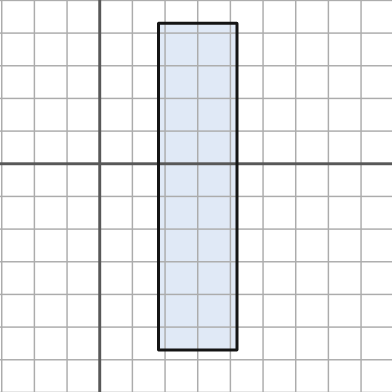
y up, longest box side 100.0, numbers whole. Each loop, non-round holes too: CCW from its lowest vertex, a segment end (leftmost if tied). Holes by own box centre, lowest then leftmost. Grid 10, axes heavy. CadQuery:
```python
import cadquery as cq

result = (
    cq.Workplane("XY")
    .moveTo(18.0, -57.0)
    .lineTo(42.0, -57.0)
    .lineTo(42.0, 43.0)
    .lineTo(18.0, 43.0)
    .close()
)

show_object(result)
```